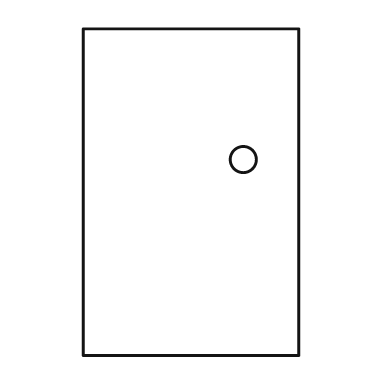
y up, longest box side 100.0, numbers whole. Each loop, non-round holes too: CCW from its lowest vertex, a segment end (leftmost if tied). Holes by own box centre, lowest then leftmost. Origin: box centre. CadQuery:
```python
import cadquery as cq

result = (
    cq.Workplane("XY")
    .moveTo(-33.0, -50.0)
    .lineTo(33.0, -50.0)
    .lineTo(33.0, 50.0)
    .lineTo(-33.0, 50.0)
    .close()
    .moveTo(16.0, 10.0)
    .circle(4.0)
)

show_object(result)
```